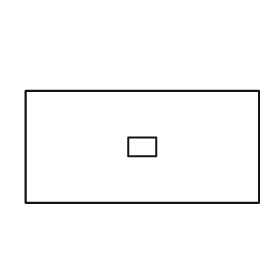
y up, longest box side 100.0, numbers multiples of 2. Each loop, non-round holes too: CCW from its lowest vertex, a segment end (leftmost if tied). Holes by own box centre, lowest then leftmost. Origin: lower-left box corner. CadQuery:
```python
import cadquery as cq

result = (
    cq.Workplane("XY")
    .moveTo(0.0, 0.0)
    .lineTo(100.0, 0.0)
    .lineTo(100.0, 48.0)
    .lineTo(0.0, 48.0)
    .close()
    .moveTo(44.0, 20.0)
    .lineTo(56.0, 20.0)
    .lineTo(56.0, 28.0)
    .lineTo(44.0, 28.0)
    .close()
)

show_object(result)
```